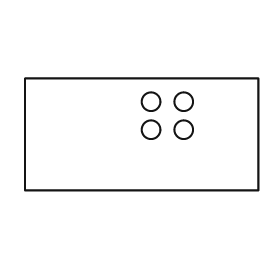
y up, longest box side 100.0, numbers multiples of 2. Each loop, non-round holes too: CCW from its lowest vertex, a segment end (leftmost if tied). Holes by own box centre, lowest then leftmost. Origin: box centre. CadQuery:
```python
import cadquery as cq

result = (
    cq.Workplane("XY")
    .moveTo(-50.0, -24.0)
    .lineTo(50.0, -24.0)
    .lineTo(50.0, 24.0)
    .lineTo(-50.0, 24.0)
    .close()
    .moveTo(4.0, 2.0)
    .circle(4.0)
    .moveTo(18.0, 2.0)
    .circle(4.0)
    .moveTo(4.0, 14.0)
    .circle(4.0)
    .moveTo(18.0, 14.0)
    .circle(4.0)
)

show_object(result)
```